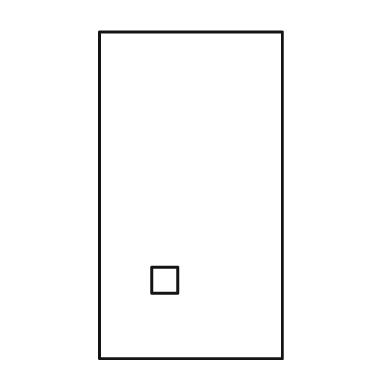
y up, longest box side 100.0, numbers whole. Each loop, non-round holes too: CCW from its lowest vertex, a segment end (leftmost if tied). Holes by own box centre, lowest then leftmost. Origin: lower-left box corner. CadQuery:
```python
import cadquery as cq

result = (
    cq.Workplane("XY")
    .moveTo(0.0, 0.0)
    .lineTo(56.0, 0.0)
    .lineTo(56.0, 100.0)
    .lineTo(0.0, 100.0)
    .close()
    .moveTo(16.0, 20.0)
    .lineTo(24.0, 20.0)
    .lineTo(24.0, 28.0)
    .lineTo(16.0, 28.0)
    .close()
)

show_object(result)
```